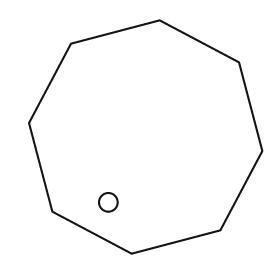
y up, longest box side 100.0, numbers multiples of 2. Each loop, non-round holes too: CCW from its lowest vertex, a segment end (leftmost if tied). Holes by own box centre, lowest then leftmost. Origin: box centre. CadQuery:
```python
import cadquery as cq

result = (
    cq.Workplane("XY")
    .moveTo(-6.0, -50.0)
    .lineTo(32.0, -40.0)
    .lineTo(50.0, -6.0)
    .lineTo(40.0, 32.0)
    .lineTo(6.0, 50.0)
    .lineTo(-32.0, 40.0)
    .lineTo(-50.0, 6.0)
    .lineTo(-40.0, -32.0)
    .close()
    .moveTo(-16.0, -28.0)
    .circle(4.0)
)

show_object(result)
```